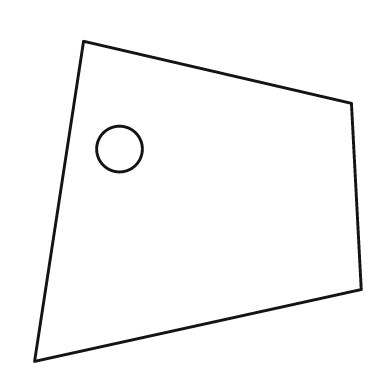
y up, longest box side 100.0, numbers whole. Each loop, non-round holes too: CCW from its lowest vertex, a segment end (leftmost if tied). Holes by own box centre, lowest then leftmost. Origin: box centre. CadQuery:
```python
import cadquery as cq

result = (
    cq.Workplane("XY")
    .moveTo(-50.0, -49.0)
    .lineTo(50.0, -27.0)
    .lineTo(47.0, 30.0)
    .lineTo(-35.0, 49.0)
    .close()
    .moveTo(-24.0, 16.0)
    .circle(7.0)
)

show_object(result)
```